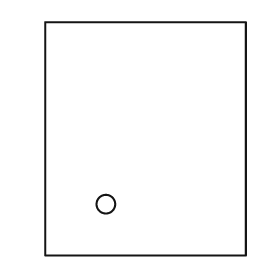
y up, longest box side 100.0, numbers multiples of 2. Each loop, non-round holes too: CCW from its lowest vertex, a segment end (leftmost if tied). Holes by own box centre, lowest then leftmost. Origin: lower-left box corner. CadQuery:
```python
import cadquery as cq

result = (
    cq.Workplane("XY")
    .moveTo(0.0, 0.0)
    .lineTo(86.0, 0.0)
    .lineTo(86.0, 100.0)
    .lineTo(0.0, 100.0)
    .close()
    .moveTo(26.0, 22.0)
    .circle(4.0)
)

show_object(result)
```